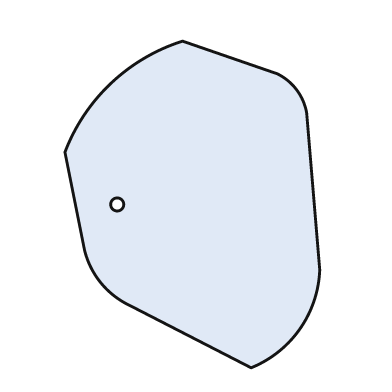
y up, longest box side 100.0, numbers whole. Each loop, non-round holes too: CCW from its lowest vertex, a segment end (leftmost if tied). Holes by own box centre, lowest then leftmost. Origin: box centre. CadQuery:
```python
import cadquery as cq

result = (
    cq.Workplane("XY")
    .moveTo(18.0, -50.0)
    .threePointArc((33.0, -38.0), (39.0, -20.0))
    .lineTo(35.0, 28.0)
    .threePointArc((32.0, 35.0), (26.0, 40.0))
    .lineTo(-3.0, 50.0)
    .threePointArc((-25.0, 37.0), (-39.0, 16.0))
    .lineTo(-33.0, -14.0)
    .threePointArc((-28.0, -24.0), (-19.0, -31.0))
    .close()
    .moveTo(-23.0, 0.0)
    .circle(2.0)
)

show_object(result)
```